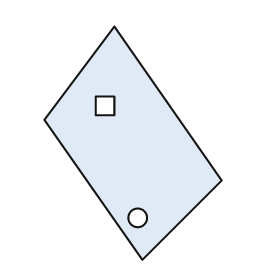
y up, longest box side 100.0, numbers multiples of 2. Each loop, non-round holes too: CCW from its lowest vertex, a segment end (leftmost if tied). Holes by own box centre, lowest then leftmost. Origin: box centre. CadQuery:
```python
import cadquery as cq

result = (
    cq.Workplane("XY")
    .moveTo(4.0, -50.0)
    .lineTo(38.0, -16.0)
    .lineTo(-8.0, 50.0)
    .lineTo(-38.0, 10.0)
    .close()
    .moveTo(2.0, -32.0)
    .circle(4.0)
    .moveTo(-16.0, 12.0)
    .lineTo(-8.0, 12.0)
    .lineTo(-8.0, 20.0)
    .lineTo(-16.0, 20.0)
    .close()
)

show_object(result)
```